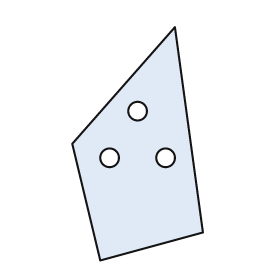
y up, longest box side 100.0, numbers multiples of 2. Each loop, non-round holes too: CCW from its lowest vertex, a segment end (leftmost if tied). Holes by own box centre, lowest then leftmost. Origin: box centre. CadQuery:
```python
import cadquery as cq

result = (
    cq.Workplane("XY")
    .moveTo(-16.0, -50.0)
    .lineTo(28.0, -38.0)
    .lineTo(16.0, 50.0)
    .lineTo(-28.0, 0.0)
    .close()
    .moveTo(-12.0, -6.0)
    .circle(4.0)
    .moveTo(12.0, -6.0)
    .circle(4.0)
    .moveTo(0.0, 14.0)
    .circle(4.0)
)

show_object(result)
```